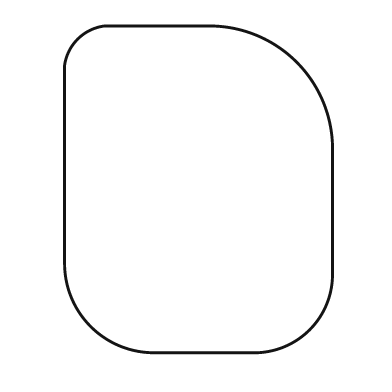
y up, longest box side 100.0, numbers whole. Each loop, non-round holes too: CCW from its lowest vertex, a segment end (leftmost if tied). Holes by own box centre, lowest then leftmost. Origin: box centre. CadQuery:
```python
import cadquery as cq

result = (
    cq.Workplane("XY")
    .moveTo(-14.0, -50.0)
    .lineTo(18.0, -50.0)
    .threePointArc((34.0, -43.0), (41.0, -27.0))
    .lineTo(41.0, 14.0)
    .threePointArc((30.0, 39.0), (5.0, 50.0))
    .lineTo(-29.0, 50.0)
    .threePointArc((-37.0, 46.0), (-41.0, 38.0))
    .lineTo(-41.0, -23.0)
    .threePointArc((-33.0, -42.0), (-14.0, -50.0))
    .close()
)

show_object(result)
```